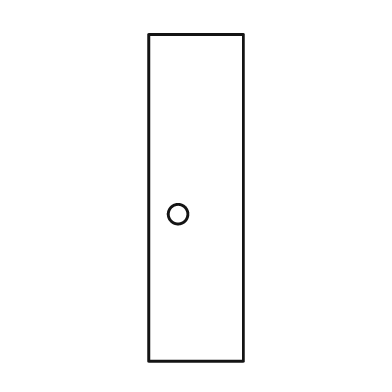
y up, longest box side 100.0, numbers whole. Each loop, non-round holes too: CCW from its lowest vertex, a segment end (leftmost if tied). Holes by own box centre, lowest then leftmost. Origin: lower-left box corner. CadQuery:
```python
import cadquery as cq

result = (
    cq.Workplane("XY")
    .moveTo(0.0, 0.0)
    .lineTo(29.0, 0.0)
    .lineTo(29.0, 100.0)
    .lineTo(0.0, 100.0)
    .close()
    .moveTo(9.0, 45.0)
    .circle(3.0)
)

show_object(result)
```